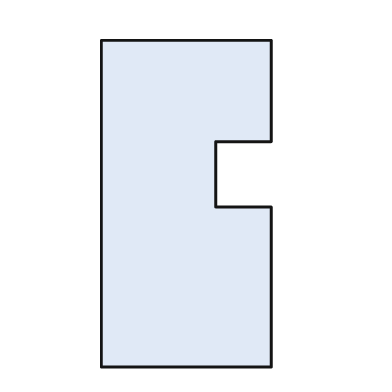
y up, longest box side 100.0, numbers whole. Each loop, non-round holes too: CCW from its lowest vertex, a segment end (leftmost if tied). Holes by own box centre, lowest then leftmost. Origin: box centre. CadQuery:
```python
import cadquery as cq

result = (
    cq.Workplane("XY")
    .moveTo(-26.0, -50.0)
    .lineTo(26.0, -50.0)
    .lineTo(26.0, -1.0)
    .lineTo(9.0, -1.0)
    .lineTo(9.0, 19.0)
    .lineTo(26.0, 19.0)
    .lineTo(26.0, 50.0)
    .lineTo(-26.0, 50.0)
    .close()
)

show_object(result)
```